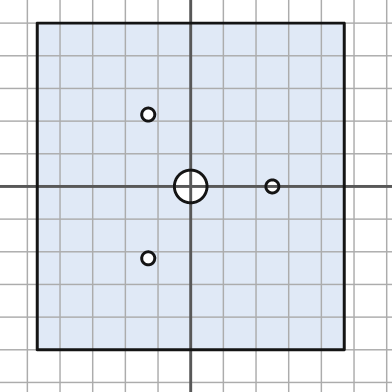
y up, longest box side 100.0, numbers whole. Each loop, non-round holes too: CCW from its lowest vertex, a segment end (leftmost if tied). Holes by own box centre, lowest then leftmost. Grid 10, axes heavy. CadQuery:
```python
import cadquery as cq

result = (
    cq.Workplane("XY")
    .moveTo(-47.0, -50.0)
    .lineTo(47.0, -50.0)
    .lineTo(47.0, 50.0)
    .lineTo(-47.0, 50.0)
    .close()
    .moveTo(-13.0, -22.0)
    .circle(2.0)
    .moveTo(0.0, 0.0)
    .circle(5.0)
    .moveTo(25.0, 0.0)
    .circle(2.0)
    .moveTo(-13.0, 22.0)
    .circle(2.0)
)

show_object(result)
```